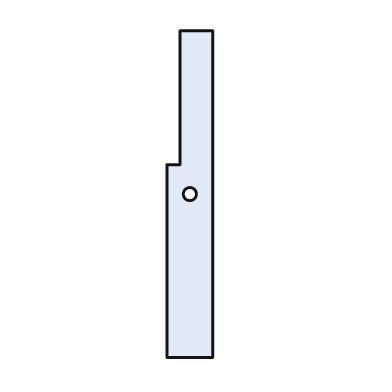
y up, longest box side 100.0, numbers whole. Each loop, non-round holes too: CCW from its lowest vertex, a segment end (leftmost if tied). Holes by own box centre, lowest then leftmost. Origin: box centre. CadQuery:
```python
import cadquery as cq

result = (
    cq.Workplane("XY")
    .moveTo(-7.0, -50.0)
    .lineTo(7.0, -50.0)
    .lineTo(7.0, 50.0)
    .lineTo(-3.0, 50.0)
    .lineTo(-3.0, 9.0)
    .lineTo(-7.0, 9.0)
    .close()
    .moveTo(0.0, 0.0)
    .circle(2.0)
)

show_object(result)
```